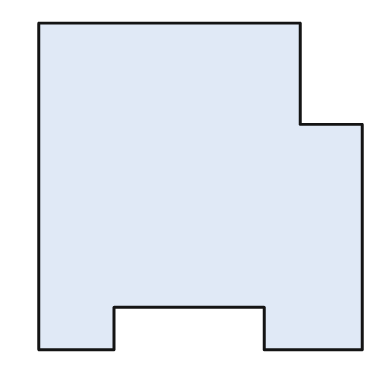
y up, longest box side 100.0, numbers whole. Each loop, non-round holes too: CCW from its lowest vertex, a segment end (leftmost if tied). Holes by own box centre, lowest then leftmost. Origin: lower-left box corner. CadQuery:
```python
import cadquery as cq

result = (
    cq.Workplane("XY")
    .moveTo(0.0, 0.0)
    .lineTo(23.0, 0.0)
    .lineTo(23.0, 13.0)
    .lineTo(69.0, 13.0)
    .lineTo(69.0, 0.0)
    .lineTo(99.0, 0.0)
    .lineTo(99.0, 69.0)
    .lineTo(80.0, 69.0)
    .lineTo(80.0, 100.0)
    .lineTo(0.0, 100.0)
    .close()
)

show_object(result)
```